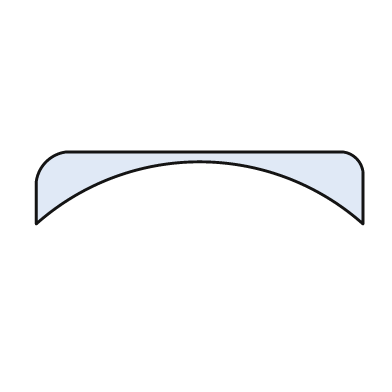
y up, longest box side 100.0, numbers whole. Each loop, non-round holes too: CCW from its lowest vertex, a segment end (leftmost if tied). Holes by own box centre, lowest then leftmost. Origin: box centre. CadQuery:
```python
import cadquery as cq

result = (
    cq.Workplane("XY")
    .moveTo(-50.0, -11.0)
    .threePointArc((0.0, 8.0), (50.0, -11.0))
    .lineTo(50.0, 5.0)
    .threePointArc((48.0, 9.0), (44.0, 11.0))
    .lineTo(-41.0, 11.0)
    .threePointArc((-47.0, 8.0), (-50.0, 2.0))
    .close()
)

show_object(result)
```